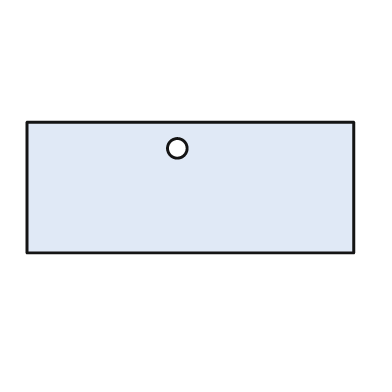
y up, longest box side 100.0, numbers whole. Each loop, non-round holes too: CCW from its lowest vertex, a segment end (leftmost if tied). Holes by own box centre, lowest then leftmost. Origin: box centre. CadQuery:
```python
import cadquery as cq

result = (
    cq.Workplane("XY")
    .moveTo(-50.0, -20.0)
    .lineTo(50.0, -20.0)
    .lineTo(50.0, 20.0)
    .lineTo(-50.0, 20.0)
    .close()
    .moveTo(-4.0, 12.0)
    .circle(3.0)
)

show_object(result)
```